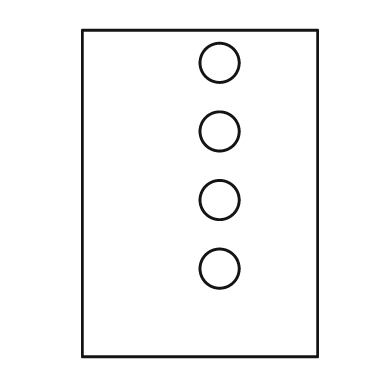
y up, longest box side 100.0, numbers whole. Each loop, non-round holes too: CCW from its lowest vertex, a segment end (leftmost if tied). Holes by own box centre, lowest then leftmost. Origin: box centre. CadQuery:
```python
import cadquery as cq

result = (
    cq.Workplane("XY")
    .moveTo(-36.0, -50.0)
    .lineTo(36.0, -50.0)
    .lineTo(36.0, 50.0)
    .lineTo(-36.0, 50.0)
    .close()
    .moveTo(6.0, -23.0)
    .circle(6.0)
    .moveTo(6.0, -2.0)
    .circle(6.0)
    .moveTo(6.0, 19.0)
    .circle(6.0)
    .moveTo(6.0, 40.0)
    .circle(6.0)
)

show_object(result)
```